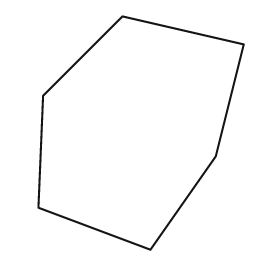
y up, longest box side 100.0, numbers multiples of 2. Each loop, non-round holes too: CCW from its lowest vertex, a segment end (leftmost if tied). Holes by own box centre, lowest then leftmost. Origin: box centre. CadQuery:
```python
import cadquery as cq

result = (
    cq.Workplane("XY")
    .moveTo(4.0, -50.0)
    .lineTo(32.0, -10.0)
    .lineTo(44.0, 38.0)
    .lineTo(-8.0, 50.0)
    .lineTo(-42.0, 16.0)
    .lineTo(-44.0, -32.0)
    .close()
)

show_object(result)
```